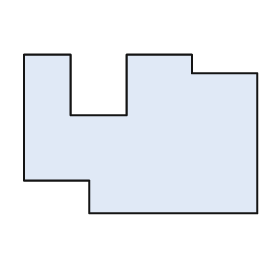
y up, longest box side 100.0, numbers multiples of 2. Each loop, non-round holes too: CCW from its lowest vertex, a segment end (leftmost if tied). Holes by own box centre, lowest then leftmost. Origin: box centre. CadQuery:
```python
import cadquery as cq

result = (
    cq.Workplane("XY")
    .moveTo(-22.0, -34.0)
    .lineTo(50.0, -34.0)
    .lineTo(50.0, 26.0)
    .lineTo(22.0, 26.0)
    .lineTo(22.0, 34.0)
    .lineTo(-6.0, 34.0)
    .lineTo(-6.0, 8.0)
    .lineTo(-30.0, 8.0)
    .lineTo(-30.0, 34.0)
    .lineTo(-50.0, 34.0)
    .lineTo(-50.0, -20.0)
    .lineTo(-22.0, -20.0)
    .close()
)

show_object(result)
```